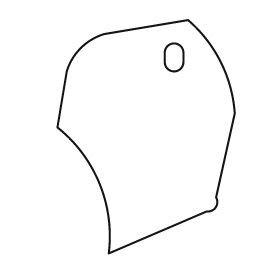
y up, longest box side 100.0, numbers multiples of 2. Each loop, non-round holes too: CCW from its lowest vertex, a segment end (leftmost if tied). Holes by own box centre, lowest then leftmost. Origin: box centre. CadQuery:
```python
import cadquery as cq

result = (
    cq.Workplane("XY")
    .moveTo(-16.0, -50.0)
    .lineTo(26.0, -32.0)
    .threePointArc((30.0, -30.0), (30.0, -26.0))
    .lineTo(38.0, 10.0)
    .threePointArc((32.0, 32.0), (18.0, 50.0))
    .lineTo(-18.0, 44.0)
    .threePointArc((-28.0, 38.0), (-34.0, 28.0))
    .lineTo(-38.0, 4.0)
    .threePointArc((-20.0, -20.0), (-16.0, -50.0))
    .close()
    .moveTo(8.0, 32.0)
    .threePointArc((12.0, 28.0), (16.0, 32.0))
    .lineTo(16.0, 36.0)
    .threePointArc((12.0, 40.0), (8.0, 36.0))
    .close()
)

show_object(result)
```